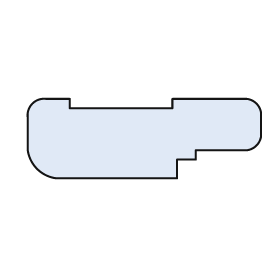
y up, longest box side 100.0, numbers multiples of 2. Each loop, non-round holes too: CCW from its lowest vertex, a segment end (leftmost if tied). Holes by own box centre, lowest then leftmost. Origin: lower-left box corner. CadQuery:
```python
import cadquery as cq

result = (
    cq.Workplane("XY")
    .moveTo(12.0, 0.0)
    .lineTo(64.0, 0.0)
    .lineTo(64.0, 8.0)
    .lineTo(72.0, 8.0)
    .lineTo(72.0, 12.0)
    .lineTo(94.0, 12.0)
    .threePointArc((98.0, 14.0), (100.0, 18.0))
    .lineTo(100.0, 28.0)
    .threePointArc((98.0, 32.0), (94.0, 34.0))
    .lineTo(62.0, 34.0)
    .lineTo(62.0, 30.0)
    .lineTo(18.0, 30.0)
    .lineTo(18.0, 34.0)
    .lineTo(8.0, 34.0)
    .threePointArc((2.0, 32.0), (0.0, 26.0))
    .lineTo(0.0, 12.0)
    .threePointArc((4.0, 4.0), (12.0, 0.0))
    .close()
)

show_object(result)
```